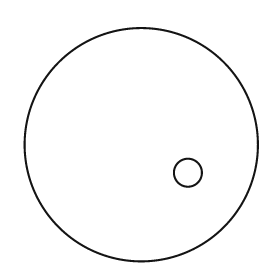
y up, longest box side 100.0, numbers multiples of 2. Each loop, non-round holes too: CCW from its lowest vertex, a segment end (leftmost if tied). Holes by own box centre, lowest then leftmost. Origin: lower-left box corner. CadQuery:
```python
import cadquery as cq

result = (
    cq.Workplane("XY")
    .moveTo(50.0, 50.0)
    .circle(50.0)
    .moveTo(70.0, 38.0)
    .circle(6.0)
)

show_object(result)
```